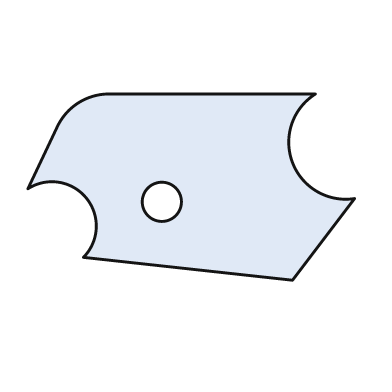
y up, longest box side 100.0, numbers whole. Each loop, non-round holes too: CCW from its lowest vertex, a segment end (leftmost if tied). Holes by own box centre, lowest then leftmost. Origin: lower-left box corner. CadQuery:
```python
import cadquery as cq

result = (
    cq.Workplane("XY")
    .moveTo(81.0, 0.0)
    .lineTo(100.0, 25.0)
    .threePointArc((81.0, 36.0), (88.0, 57.0))
    .lineTo(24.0, 57.0)
    .threePointArc((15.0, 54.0), (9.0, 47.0))
    .lineTo(0.0, 28.0)
    .threePointArc((18.0, 25.0), (17.0, 7.0))
    .close()
    .moveTo(41.0, 24.0)
    .circle(6.0)
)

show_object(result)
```